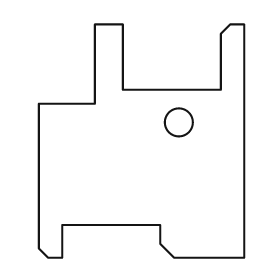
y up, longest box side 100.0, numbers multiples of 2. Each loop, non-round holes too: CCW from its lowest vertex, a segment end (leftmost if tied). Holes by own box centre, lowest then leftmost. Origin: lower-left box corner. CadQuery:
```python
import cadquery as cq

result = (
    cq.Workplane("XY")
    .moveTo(4.0, 0.0)
    .lineTo(10.0, 0.0)
    .lineTo(10.0, 14.0)
    .lineTo(52.0, 14.0)
    .lineTo(52.0, 6.0)
    .lineTo(58.0, 0.0)
    .lineTo(88.0, 0.0)
    .lineTo(88.0, 100.0)
    .lineTo(82.0, 100.0)
    .lineTo(78.0, 96.0)
    .lineTo(78.0, 72.0)
    .lineTo(36.0, 72.0)
    .lineTo(36.0, 100.0)
    .lineTo(24.0, 100.0)
    .lineTo(24.0, 66.0)
    .lineTo(0.0, 66.0)
    .lineTo(0.0, 4.0)
    .close()
    .moveTo(60.0, 58.0)
    .circle(6.0)
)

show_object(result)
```